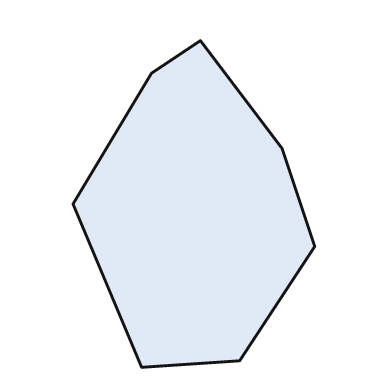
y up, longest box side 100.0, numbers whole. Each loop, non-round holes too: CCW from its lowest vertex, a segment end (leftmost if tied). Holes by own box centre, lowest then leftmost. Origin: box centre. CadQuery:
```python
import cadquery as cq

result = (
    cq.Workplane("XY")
    .moveTo(-16.0, -50.0)
    .lineTo(14.0, -48.0)
    .lineTo(37.0, -13.0)
    .lineTo(27.0, 17.0)
    .lineTo(2.0, 50.0)
    .lineTo(-13.0, 40.0)
    .lineTo(-37.0, 0.0)
    .close()
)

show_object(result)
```